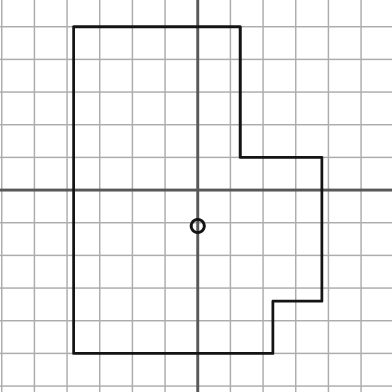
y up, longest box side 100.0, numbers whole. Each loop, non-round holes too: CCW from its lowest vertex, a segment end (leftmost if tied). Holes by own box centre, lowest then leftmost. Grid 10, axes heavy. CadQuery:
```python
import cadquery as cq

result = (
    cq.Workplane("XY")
    .moveTo(-38.0, -50.0)
    .lineTo(23.0, -50.0)
    .lineTo(23.0, -34.0)
    .lineTo(38.0, -34.0)
    .lineTo(38.0, 10.0)
    .lineTo(13.0, 10.0)
    .lineTo(13.0, 50.0)
    .lineTo(-38.0, 50.0)
    .close()
    .moveTo(0.0, -11.0)
    .circle(2.0)
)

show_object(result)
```